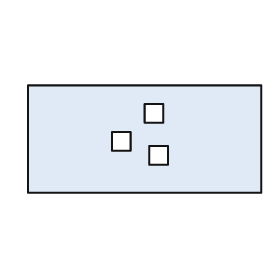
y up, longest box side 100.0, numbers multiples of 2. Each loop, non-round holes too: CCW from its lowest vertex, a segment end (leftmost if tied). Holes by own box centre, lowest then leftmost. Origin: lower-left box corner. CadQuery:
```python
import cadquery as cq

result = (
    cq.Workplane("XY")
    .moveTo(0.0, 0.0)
    .lineTo(100.0, 0.0)
    .lineTo(100.0, 46.0)
    .lineTo(0.0, 46.0)
    .close()
    .moveTo(52.0, 12.0)
    .lineTo(60.0, 12.0)
    .lineTo(60.0, 20.0)
    .lineTo(52.0, 20.0)
    .close()
    .moveTo(36.0, 18.0)
    .lineTo(44.0, 18.0)
    .lineTo(44.0, 26.0)
    .lineTo(36.0, 26.0)
    .close()
    .moveTo(50.0, 30.0)
    .lineTo(58.0, 30.0)
    .lineTo(58.0, 38.0)
    .lineTo(50.0, 38.0)
    .close()
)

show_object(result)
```